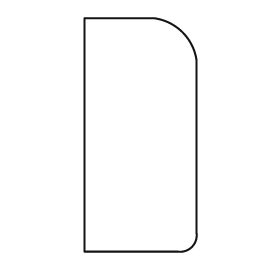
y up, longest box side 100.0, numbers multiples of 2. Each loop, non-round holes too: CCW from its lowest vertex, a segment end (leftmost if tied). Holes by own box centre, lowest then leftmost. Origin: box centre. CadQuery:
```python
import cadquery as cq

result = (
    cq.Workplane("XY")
    .moveTo(-24.0, -50.0)
    .lineTo(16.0, -50.0)
    .threePointArc((22.0, -48.0), (24.0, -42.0))
    .lineTo(24.0, 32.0)
    .threePointArc((18.0, 44.0), (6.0, 50.0))
    .lineTo(-24.0, 50.0)
    .close()
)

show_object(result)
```